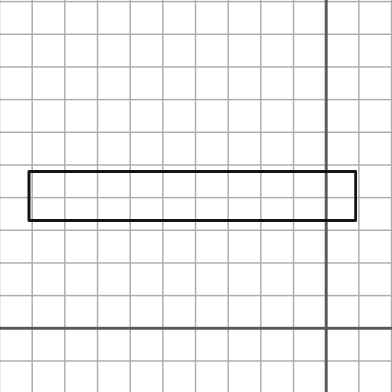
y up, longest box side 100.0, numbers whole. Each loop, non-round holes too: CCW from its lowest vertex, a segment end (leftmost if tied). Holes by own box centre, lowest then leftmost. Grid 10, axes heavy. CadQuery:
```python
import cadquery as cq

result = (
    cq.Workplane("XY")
    .moveTo(-91.0, 33.0)
    .lineTo(9.0, 33.0)
    .lineTo(9.0, 48.0)
    .lineTo(-91.0, 48.0)
    .close()
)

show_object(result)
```